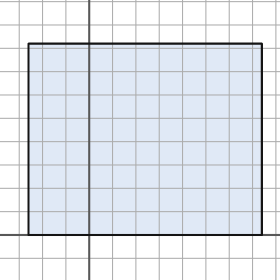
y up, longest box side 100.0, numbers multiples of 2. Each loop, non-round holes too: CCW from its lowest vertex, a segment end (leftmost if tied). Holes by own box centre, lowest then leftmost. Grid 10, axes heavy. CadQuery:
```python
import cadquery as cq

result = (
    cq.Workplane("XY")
    .moveTo(-26.0, 0.0)
    .lineTo(74.0, 0.0)
    .lineTo(74.0, 82.0)
    .lineTo(-26.0, 82.0)
    .close()
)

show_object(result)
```